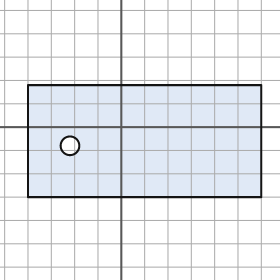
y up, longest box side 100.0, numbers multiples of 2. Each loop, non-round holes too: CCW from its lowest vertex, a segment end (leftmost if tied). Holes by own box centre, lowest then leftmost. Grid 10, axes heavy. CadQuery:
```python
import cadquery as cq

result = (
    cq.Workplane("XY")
    .moveTo(-40.0, -30.0)
    .lineTo(60.0, -30.0)
    .lineTo(60.0, 18.0)
    .lineTo(-40.0, 18.0)
    .close()
    .moveTo(-22.0, -8.0)
    .circle(4.0)
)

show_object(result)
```